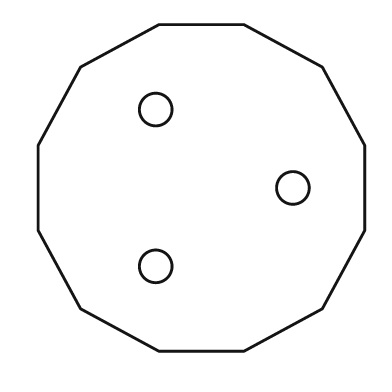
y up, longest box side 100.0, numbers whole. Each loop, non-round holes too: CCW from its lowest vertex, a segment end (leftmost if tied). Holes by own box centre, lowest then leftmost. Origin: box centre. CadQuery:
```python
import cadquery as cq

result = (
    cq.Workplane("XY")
    .moveTo(-13.0, -50.0)
    .lineTo(13.0, -50.0)
    .lineTo(37.0, -37.0)
    .lineTo(50.0, -13.0)
    .lineTo(50.0, 13.0)
    .lineTo(37.0, 37.0)
    .lineTo(13.0, 50.0)
    .lineTo(-13.0, 50.0)
    .lineTo(-37.0, 37.0)
    .lineTo(-50.0, 13.0)
    .lineTo(-50.0, -13.0)
    .lineTo(-37.0, -37.0)
    .close()
    .moveTo(-14.0, -24.0)
    .circle(5.0)
    .moveTo(28.0, 0.0)
    .circle(5.0)
    .moveTo(-14.0, 24.0)
    .circle(5.0)
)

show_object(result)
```